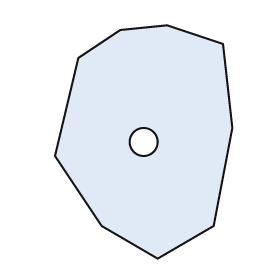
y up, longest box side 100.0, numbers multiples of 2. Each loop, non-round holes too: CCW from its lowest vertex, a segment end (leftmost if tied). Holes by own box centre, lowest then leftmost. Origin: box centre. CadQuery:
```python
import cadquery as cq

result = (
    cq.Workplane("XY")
    .moveTo(6.0, -50.0)
    .lineTo(30.0, -36.0)
    .lineTo(38.0, 6.0)
    .lineTo(34.0, 42.0)
    .lineTo(10.0, 50.0)
    .lineTo(-10.0, 48.0)
    .lineTo(-28.0, 36.0)
    .lineTo(-38.0, -6.0)
    .lineTo(-18.0, -36.0)
    .close()
    .moveTo(0.0, 0.0)
    .circle(6.0)
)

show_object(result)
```